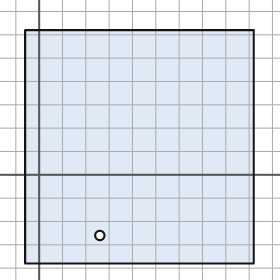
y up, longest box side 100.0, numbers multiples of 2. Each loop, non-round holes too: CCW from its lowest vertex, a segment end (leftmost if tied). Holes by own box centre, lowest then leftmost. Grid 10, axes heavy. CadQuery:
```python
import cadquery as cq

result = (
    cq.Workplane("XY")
    .moveTo(-6.0, -38.0)
    .lineTo(92.0, -38.0)
    .lineTo(92.0, 62.0)
    .lineTo(-6.0, 62.0)
    .close()
    .moveTo(26.0, -26.0)
    .circle(2.0)
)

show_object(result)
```